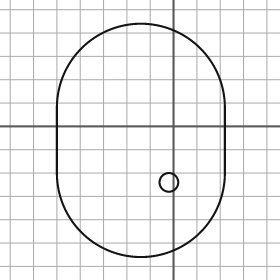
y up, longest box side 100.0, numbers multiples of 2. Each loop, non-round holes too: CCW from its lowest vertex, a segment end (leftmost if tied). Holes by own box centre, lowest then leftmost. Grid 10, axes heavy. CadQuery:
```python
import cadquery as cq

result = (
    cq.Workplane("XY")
    .moveTo(-50.0, -20.0)
    .threePointArc((-14.0, -56.0), (22.0, -20.0))
    .lineTo(22.0, 8.0)
    .threePointArc((-14.0, 44.0), (-50.0, 8.0))
    .close()
    .moveTo(-2.0, -24.0)
    .circle(4.0)
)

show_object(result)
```